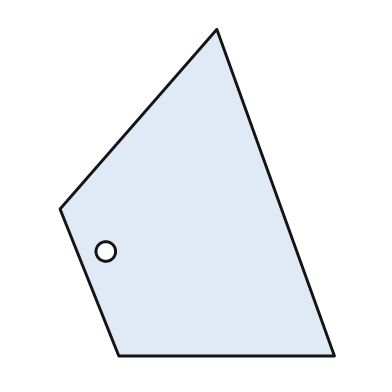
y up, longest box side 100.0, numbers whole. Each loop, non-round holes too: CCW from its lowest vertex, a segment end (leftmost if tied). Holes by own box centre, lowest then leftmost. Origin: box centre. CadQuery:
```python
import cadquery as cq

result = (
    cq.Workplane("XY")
    .moveTo(-24.0, -50.0)
    .lineTo(42.0, -50.0)
    .lineTo(6.0, 50.0)
    .lineTo(-42.0, -5.0)
    .close()
    .moveTo(-28.0, -18.0)
    .circle(3.0)
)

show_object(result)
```